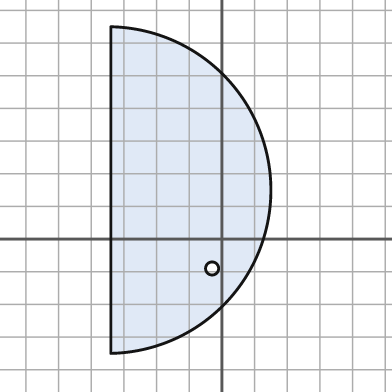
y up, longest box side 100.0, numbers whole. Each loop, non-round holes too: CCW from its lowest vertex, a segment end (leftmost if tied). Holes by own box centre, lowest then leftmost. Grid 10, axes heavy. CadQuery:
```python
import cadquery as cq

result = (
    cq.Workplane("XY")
    .moveTo(-34.0, -35.0)
    .threePointArc((15.0, 15.0), (-34.0, 65.0))
    .close()
    .moveTo(-3.0, -9.0)
    .circle(2.0)
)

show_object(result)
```